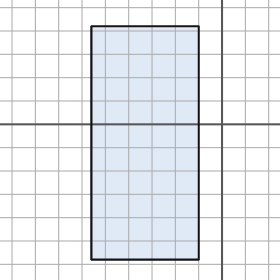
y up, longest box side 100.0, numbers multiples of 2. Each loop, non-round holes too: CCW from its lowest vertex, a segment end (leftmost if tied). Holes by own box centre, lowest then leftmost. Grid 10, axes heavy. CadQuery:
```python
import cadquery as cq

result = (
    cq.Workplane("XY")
    .moveTo(-56.0, -58.0)
    .lineTo(-10.0, -58.0)
    .lineTo(-10.0, 42.0)
    .lineTo(-56.0, 42.0)
    .close()
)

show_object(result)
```